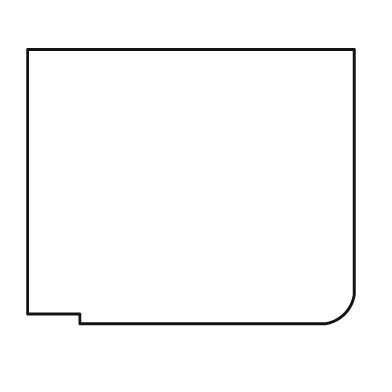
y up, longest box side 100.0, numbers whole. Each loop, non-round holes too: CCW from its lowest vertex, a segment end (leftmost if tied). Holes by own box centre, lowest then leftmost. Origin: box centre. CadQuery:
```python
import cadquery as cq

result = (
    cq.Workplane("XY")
    .moveTo(-34.0, -42.0)
    .lineTo(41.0, -42.0)
    .threePointArc((47.0, -39.0), (50.0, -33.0))
    .lineTo(50.0, 42.0)
    .lineTo(-50.0, 42.0)
    .lineTo(-50.0, -39.0)
    .lineTo(-34.0, -39.0)
    .close()
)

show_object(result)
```